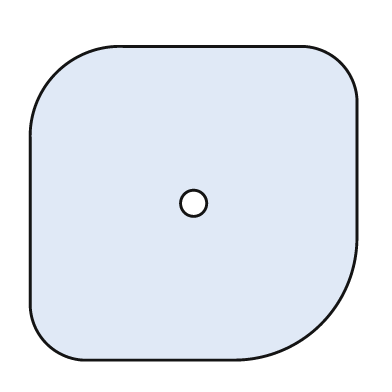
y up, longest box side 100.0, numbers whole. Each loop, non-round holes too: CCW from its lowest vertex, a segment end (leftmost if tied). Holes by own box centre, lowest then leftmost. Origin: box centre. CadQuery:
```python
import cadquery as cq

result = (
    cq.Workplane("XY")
    .moveTo(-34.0, -48.0)
    .lineTo(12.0, -48.0)
    .threePointArc((39.0, -37.0), (50.0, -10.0))
    .lineTo(50.0, 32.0)
    .threePointArc((45.0, 43.0), (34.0, 48.0))
    .lineTo(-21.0, 48.0)
    .threePointArc((-42.0, 40.0), (-50.0, 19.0))
    .lineTo(-50.0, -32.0)
    .threePointArc((-45.0, -43.0), (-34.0, -48.0))
    .close()
    .moveTo(0.0, 0.0)
    .circle(4.0)
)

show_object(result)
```